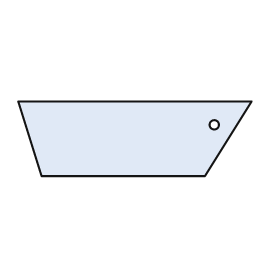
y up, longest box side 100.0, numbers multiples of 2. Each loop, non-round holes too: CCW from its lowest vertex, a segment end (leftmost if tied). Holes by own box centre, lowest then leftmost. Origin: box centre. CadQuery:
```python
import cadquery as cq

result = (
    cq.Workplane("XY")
    .moveTo(-40.0, -16.0)
    .lineTo(30.0, -16.0)
    .lineTo(50.0, 16.0)
    .lineTo(-50.0, 16.0)
    .close()
    .moveTo(34.0, 6.0)
    .circle(2.0)
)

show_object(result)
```